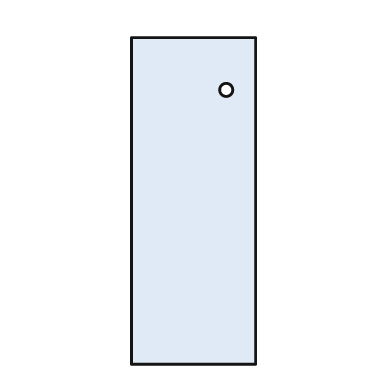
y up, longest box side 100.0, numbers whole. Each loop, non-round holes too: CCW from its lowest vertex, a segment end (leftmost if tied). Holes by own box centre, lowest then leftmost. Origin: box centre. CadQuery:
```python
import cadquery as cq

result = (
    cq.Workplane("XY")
    .moveTo(-19.0, -50.0)
    .lineTo(19.0, -50.0)
    .lineTo(19.0, 50.0)
    .lineTo(-19.0, 50.0)
    .close()
    .moveTo(10.0, 34.0)
    .circle(2.0)
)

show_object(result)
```